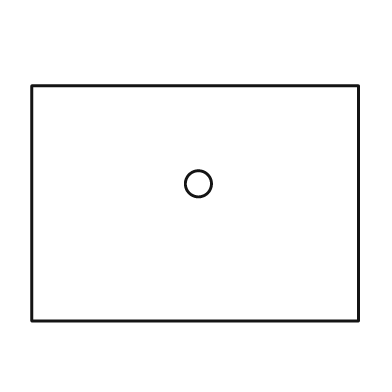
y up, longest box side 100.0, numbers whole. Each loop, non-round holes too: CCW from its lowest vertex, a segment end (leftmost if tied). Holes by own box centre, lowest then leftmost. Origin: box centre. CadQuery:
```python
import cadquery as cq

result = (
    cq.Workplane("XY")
    .moveTo(-50.0, -36.0)
    .lineTo(50.0, -36.0)
    .lineTo(50.0, 36.0)
    .lineTo(-50.0, 36.0)
    .close()
    .moveTo(1.0, 6.0)
    .circle(4.0)
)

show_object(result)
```